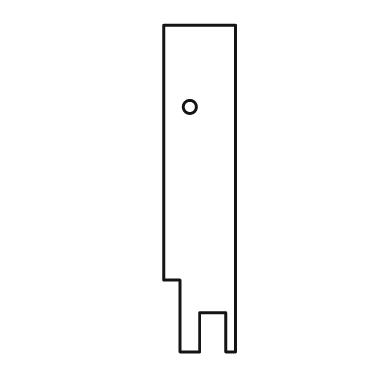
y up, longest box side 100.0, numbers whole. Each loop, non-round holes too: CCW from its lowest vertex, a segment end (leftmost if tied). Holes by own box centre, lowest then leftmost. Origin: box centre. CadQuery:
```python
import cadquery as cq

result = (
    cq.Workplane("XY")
    .moveTo(-6.0, -50.0)
    .lineTo(0.0, -50.0)
    .lineTo(0.0, -38.0)
    .lineTo(8.0, -38.0)
    .lineTo(8.0, -50.0)
    .lineTo(11.0, -50.0)
    .lineTo(11.0, 50.0)
    .lineTo(-11.0, 50.0)
    .lineTo(-11.0, -28.0)
    .lineTo(-6.0, -28.0)
    .close()
    .moveTo(-3.0, 25.0)
    .circle(2.0)
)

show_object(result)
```